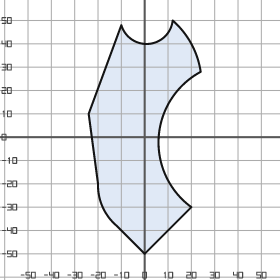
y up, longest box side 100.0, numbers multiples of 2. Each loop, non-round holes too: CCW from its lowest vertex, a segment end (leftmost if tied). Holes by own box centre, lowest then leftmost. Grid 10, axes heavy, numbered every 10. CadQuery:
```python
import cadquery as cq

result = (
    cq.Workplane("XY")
    .moveTo(0.0, -50.0)
    .lineTo(20.0, -30.0)
    .threePointArc((6.0, 0.0), (24.0, 28.0))
    .threePointArc((20.0, 40.0), (12.0, 50.0))
    .threePointArc((2.0, 40.0), (-10.0, 48.0))
    .lineTo(-24.0, 10.0)
    .lineTo(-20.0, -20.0)
    .threePointArc((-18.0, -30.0), (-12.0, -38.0))
    .close()
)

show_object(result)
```